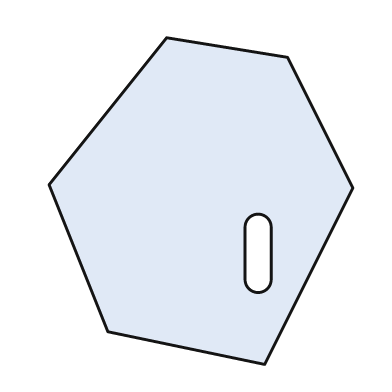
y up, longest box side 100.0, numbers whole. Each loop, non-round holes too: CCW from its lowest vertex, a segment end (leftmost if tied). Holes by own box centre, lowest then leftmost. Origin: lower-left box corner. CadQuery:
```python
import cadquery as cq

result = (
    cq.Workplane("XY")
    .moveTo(66.0, 0.0)
    .lineTo(93.0, 54.0)
    .lineTo(73.0, 94.0)
    .lineTo(36.0, 100.0)
    .lineTo(0.0, 55.0)
    .lineTo(18.0, 10.0)
    .close()
    .moveTo(60.0, 26.0)
    .threePointArc((64.0, 22.0), (68.0, 26.0))
    .lineTo(68.0, 42.0)
    .threePointArc((64.0, 46.0), (60.0, 42.0))
    .close()
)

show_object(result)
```